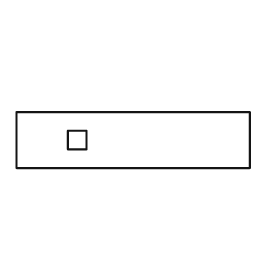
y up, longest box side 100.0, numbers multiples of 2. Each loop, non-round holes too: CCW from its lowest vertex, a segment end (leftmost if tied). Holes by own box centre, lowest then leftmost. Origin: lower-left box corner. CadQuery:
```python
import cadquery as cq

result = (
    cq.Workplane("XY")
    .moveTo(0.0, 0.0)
    .lineTo(100.0, 0.0)
    .lineTo(100.0, 24.0)
    .lineTo(0.0, 24.0)
    .close()
    .moveTo(22.0, 8.0)
    .lineTo(30.0, 8.0)
    .lineTo(30.0, 16.0)
    .lineTo(22.0, 16.0)
    .close()
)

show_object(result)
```